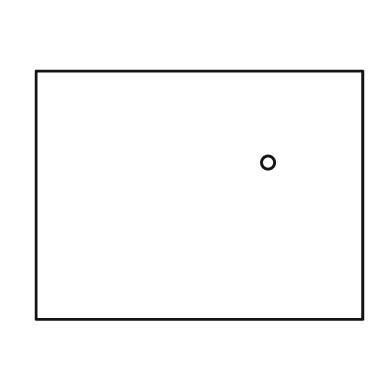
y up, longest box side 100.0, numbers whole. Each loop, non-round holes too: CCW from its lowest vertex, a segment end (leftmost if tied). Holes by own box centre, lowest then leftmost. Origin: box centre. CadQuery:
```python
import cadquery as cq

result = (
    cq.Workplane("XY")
    .moveTo(-50.0, -38.0)
    .lineTo(50.0, -38.0)
    .lineTo(50.0, 38.0)
    .lineTo(-50.0, 38.0)
    .close()
    .moveTo(21.0, 10.0)
    .circle(2.0)
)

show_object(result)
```